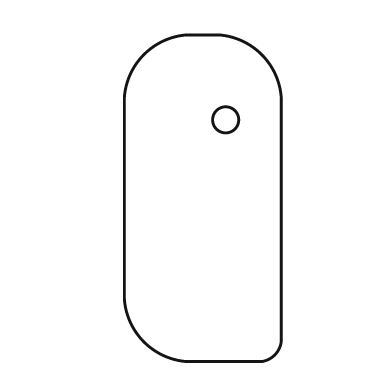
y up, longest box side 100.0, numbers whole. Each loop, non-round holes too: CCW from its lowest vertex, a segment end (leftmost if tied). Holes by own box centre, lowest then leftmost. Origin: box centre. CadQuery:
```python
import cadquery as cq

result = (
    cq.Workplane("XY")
    .moveTo(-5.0, -50.0)
    .lineTo(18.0, -50.0)
    .threePointArc((22.0, -48.0), (24.0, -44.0))
    .lineTo(24.0, 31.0)
    .threePointArc((18.0, 44.0), (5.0, 50.0))
    .lineTo(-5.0, 50.0)
    .threePointArc((-18.0, 44.0), (-24.0, 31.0))
    .lineTo(-24.0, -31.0)
    .threePointArc((-18.0, -44.0), (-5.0, -50.0))
    .close()
    .moveTo(7.0, 24.0)
    .circle(4.0)
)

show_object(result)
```